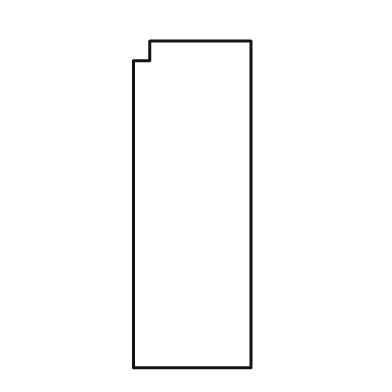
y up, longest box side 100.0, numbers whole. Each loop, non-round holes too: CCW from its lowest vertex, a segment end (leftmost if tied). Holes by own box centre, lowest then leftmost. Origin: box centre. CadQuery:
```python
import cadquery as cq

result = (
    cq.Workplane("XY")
    .moveTo(-18.0, -50.0)
    .lineTo(18.0, -50.0)
    .lineTo(18.0, 50.0)
    .lineTo(-13.0, 50.0)
    .lineTo(-13.0, 44.0)
    .lineTo(-18.0, 44.0)
    .close()
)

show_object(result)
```